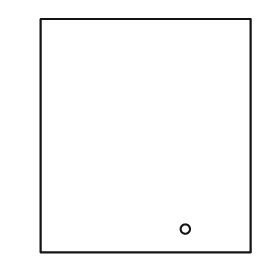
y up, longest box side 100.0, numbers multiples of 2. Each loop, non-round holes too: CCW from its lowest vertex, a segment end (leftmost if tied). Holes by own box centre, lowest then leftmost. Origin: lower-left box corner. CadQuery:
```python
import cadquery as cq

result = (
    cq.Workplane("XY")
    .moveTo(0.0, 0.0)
    .lineTo(90.0, 0.0)
    .lineTo(90.0, 100.0)
    .lineTo(0.0, 100.0)
    .close()
    .moveTo(62.0, 10.0)
    .circle(2.0)
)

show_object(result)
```